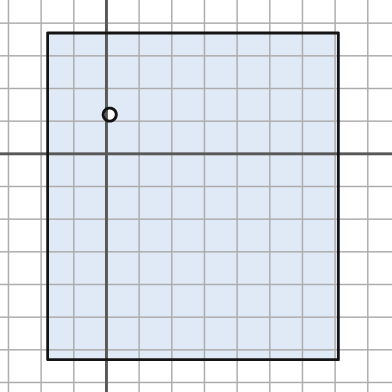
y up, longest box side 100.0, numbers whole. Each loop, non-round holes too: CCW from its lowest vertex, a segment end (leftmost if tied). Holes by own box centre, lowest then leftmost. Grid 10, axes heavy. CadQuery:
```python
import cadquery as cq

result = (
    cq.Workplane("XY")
    .moveTo(-18.0, -63.0)
    .lineTo(71.0, -63.0)
    .lineTo(71.0, 37.0)
    .lineTo(-18.0, 37.0)
    .close()
    .moveTo(1.0, 12.0)
    .circle(2.0)
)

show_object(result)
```